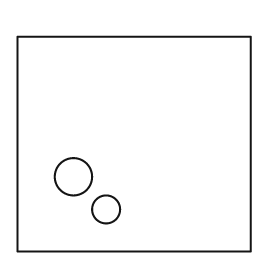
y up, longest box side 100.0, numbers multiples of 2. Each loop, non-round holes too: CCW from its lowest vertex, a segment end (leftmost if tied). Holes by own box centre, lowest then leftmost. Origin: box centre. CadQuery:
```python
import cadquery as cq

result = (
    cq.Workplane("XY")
    .moveTo(-50.0, -46.0)
    .lineTo(50.0, -46.0)
    .lineTo(50.0, 46.0)
    .lineTo(-50.0, 46.0)
    .close()
    .moveTo(-12.0, -28.0)
    .circle(6.0)
    .moveTo(-26.0, -14.0)
    .circle(8.0)
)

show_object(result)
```